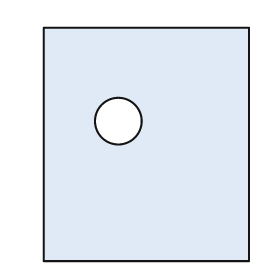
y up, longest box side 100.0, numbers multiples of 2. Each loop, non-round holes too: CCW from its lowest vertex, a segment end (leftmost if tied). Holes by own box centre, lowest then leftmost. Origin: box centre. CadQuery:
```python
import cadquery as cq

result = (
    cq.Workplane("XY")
    .moveTo(-44.0, -50.0)
    .lineTo(44.0, -50.0)
    .lineTo(44.0, 50.0)
    .lineTo(-44.0, 50.0)
    .close()
    .moveTo(-12.0, 10.0)
    .circle(10.0)
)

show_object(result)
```